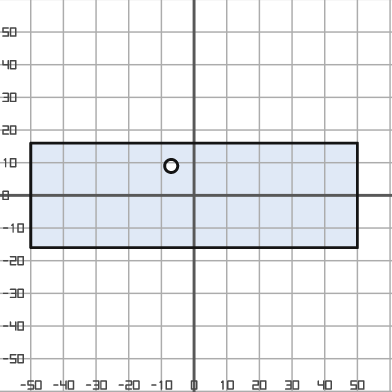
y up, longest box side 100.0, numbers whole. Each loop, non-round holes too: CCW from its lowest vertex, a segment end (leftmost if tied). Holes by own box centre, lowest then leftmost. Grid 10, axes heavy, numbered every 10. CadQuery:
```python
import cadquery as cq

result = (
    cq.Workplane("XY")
    .moveTo(-50.0, -16.0)
    .lineTo(50.0, -16.0)
    .lineTo(50.0, 16.0)
    .lineTo(-50.0, 16.0)
    .close()
    .moveTo(-7.0, 9.0)
    .circle(2.0)
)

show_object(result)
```